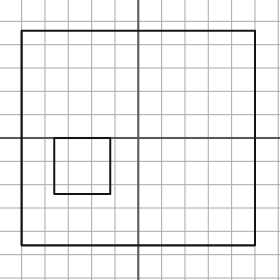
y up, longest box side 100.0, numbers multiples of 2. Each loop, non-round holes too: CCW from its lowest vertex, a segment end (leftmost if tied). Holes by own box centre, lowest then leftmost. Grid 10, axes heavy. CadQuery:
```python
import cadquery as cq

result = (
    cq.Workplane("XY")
    .moveTo(-50.0, -46.0)
    .lineTo(50.0, -46.0)
    .lineTo(50.0, 46.0)
    .lineTo(-50.0, 46.0)
    .close()
    .moveTo(-36.0, -24.0)
    .lineTo(-12.0, -24.0)
    .lineTo(-12.0, 0.0)
    .lineTo(-36.0, 0.0)
    .close()
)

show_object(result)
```